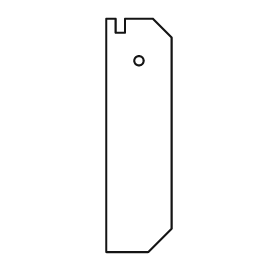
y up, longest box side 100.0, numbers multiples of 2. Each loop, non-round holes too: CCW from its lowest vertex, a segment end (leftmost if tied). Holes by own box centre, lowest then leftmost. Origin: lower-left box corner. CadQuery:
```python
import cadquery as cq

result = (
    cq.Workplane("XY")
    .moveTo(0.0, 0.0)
    .lineTo(18.0, 0.0)
    .lineTo(28.0, 10.0)
    .lineTo(28.0, 92.0)
    .lineTo(20.0, 100.0)
    .lineTo(8.0, 100.0)
    .lineTo(8.0, 94.0)
    .lineTo(4.0, 94.0)
    .lineTo(4.0, 100.0)
    .lineTo(0.0, 100.0)
    .close()
    .moveTo(14.0, 82.0)
    .circle(2.0)
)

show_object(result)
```